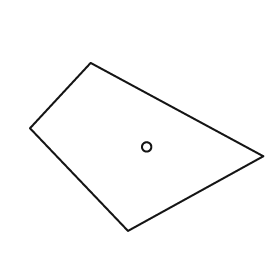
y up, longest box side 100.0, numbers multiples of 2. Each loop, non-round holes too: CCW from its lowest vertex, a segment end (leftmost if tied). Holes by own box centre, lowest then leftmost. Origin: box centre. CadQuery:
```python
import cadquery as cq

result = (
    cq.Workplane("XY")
    .moveTo(-8.0, -36.0)
    .lineTo(50.0, -4.0)
    .lineTo(-24.0, 36.0)
    .lineTo(-50.0, 8.0)
    .close()
    .moveTo(0.0, 0.0)
    .circle(2.0)
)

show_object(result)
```